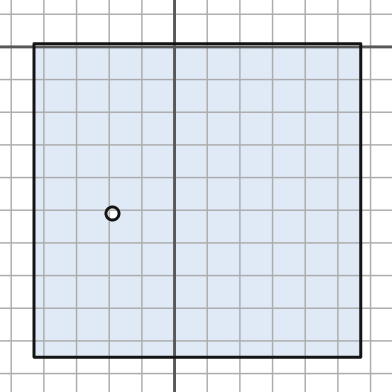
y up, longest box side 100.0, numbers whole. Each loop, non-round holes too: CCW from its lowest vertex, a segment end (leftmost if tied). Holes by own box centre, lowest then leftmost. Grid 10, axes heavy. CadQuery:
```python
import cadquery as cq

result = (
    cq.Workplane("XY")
    .moveTo(-43.0, -95.0)
    .lineTo(57.0, -95.0)
    .lineTo(57.0, 1.0)
    .lineTo(-43.0, 1.0)
    .close()
    .moveTo(-19.0, -51.0)
    .circle(2.0)
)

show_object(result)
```